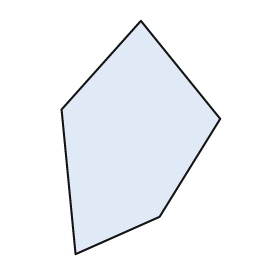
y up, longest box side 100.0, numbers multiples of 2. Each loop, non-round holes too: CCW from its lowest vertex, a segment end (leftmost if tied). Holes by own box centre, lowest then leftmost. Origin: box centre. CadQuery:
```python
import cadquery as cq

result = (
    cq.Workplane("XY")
    .moveTo(-28.0, -50.0)
    .lineTo(8.0, -34.0)
    .lineTo(34.0, 8.0)
    .lineTo(0.0, 50.0)
    .lineTo(-34.0, 12.0)
    .close()
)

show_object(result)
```